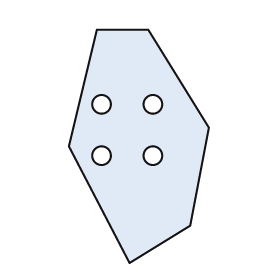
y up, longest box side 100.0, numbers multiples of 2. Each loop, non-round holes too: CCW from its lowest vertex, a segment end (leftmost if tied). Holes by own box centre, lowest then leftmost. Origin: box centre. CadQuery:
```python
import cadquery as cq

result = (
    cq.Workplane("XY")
    .moveTo(-4.0, -50.0)
    .lineTo(22.0, -34.0)
    .lineTo(30.0, 8.0)
    .lineTo(4.0, 50.0)
    .lineTo(-18.0, 50.0)
    .lineTo(-30.0, 0.0)
    .close()
    .moveTo(-16.0, -4.0)
    .circle(4.0)
    .moveTo(6.0, -4.0)
    .circle(4.0)
    .moveTo(-16.0, 18.0)
    .circle(4.0)
    .moveTo(6.0, 18.0)
    .circle(4.0)
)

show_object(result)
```